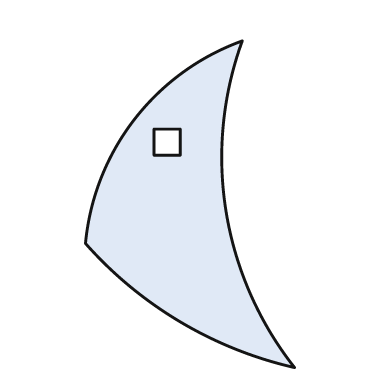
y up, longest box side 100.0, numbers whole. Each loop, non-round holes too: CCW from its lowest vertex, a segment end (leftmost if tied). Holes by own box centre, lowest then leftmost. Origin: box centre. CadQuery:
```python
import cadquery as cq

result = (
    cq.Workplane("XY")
    .moveTo(32.0, -50.0)
    .threePointArc((11.0, -2.0), (16.0, 50.0))
    .threePointArc((-17.0, 26.0), (-32.0, -12.0))
    .threePointArc((-3.0, -36.0), (32.0, -50.0))
    .close()
    .moveTo(-11.0, 15.0)
    .lineTo(-3.0, 15.0)
    .lineTo(-3.0, 23.0)
    .lineTo(-11.0, 23.0)
    .close()
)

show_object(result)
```